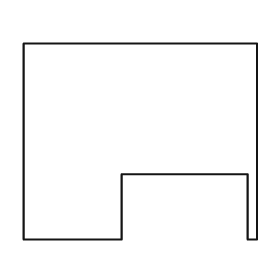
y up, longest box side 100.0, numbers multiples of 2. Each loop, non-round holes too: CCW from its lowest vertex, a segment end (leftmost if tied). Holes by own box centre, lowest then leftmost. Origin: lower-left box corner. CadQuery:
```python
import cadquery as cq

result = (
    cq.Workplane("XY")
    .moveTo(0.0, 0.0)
    .lineTo(42.0, 0.0)
    .lineTo(42.0, 28.0)
    .lineTo(96.0, 28.0)
    .lineTo(96.0, 0.0)
    .lineTo(100.0, 0.0)
    .lineTo(100.0, 84.0)
    .lineTo(0.0, 84.0)
    .close()
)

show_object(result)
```